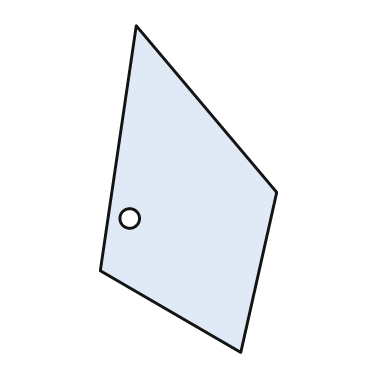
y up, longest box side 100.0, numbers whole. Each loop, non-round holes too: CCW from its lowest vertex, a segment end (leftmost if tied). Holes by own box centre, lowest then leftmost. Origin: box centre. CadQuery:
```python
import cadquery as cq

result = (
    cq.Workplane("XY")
    .moveTo(16.0, -50.0)
    .lineTo(27.0, -1.0)
    .lineTo(-16.0, 50.0)
    .lineTo(-27.0, -25.0)
    .close()
    .moveTo(-18.0, -9.0)
    .circle(3.0)
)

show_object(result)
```